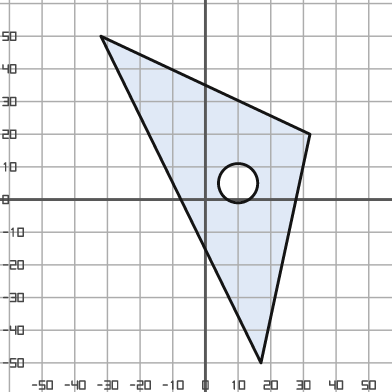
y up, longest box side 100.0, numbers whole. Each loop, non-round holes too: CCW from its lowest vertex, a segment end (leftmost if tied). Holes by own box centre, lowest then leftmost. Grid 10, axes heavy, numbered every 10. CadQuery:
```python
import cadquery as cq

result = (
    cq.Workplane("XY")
    .moveTo(17.0, -50.0)
    .lineTo(32.0, 20.0)
    .lineTo(-32.0, 50.0)
    .close()
    .moveTo(10.0, 5.0)
    .circle(6.0)
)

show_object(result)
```